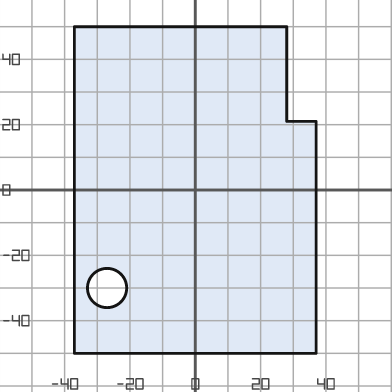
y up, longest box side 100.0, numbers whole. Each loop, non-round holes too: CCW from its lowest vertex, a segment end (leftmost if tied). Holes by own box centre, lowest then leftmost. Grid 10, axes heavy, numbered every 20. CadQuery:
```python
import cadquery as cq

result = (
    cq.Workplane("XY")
    .moveTo(-37.0, -50.0)
    .lineTo(37.0, -50.0)
    .lineTo(37.0, 21.0)
    .lineTo(28.0, 21.0)
    .lineTo(28.0, 50.0)
    .lineTo(-37.0, 50.0)
    .close()
    .moveTo(-27.0, -30.0)
    .circle(6.0)
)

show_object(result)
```